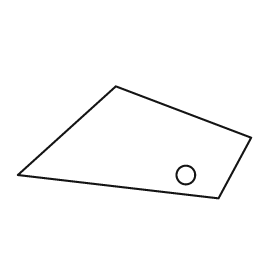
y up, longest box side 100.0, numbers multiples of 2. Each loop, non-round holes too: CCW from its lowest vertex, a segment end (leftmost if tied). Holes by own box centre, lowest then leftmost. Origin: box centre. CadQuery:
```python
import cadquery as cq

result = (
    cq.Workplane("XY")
    .moveTo(36.0, -24.0)
    .lineTo(50.0, 2.0)
    .lineTo(-8.0, 24.0)
    .lineTo(-50.0, -14.0)
    .close()
    .moveTo(22.0, -14.0)
    .circle(4.0)
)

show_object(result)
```